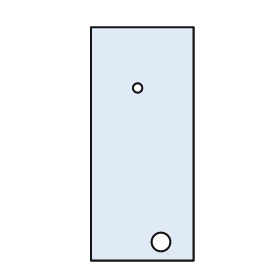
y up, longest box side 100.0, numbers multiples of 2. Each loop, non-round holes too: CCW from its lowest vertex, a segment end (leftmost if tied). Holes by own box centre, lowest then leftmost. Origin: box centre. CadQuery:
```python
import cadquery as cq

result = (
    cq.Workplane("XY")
    .moveTo(-22.0, -50.0)
    .lineTo(22.0, -50.0)
    .lineTo(22.0, 50.0)
    .lineTo(-22.0, 50.0)
    .close()
    .moveTo(8.0, -42.0)
    .circle(4.0)
    .moveTo(-2.0, 24.0)
    .circle(2.0)
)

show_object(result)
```